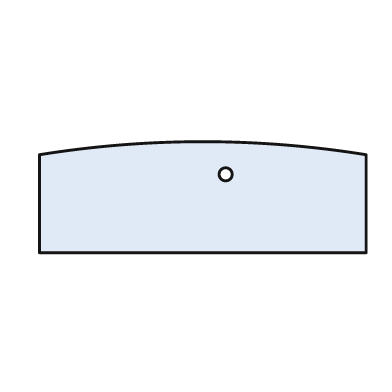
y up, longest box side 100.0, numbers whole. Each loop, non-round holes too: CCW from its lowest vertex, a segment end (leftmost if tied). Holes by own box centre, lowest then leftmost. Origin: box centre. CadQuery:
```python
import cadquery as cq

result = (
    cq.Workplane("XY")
    .moveTo(-50.0, -17.0)
    .lineTo(50.0, -17.0)
    .lineTo(50.0, 13.0)
    .threePointArc((0.0, 17.0), (-50.0, 13.0))
    .close()
    .moveTo(7.0, 7.0)
    .circle(2.0)
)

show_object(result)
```